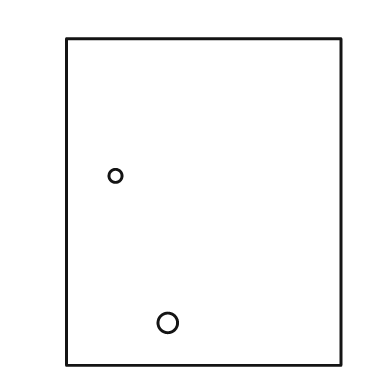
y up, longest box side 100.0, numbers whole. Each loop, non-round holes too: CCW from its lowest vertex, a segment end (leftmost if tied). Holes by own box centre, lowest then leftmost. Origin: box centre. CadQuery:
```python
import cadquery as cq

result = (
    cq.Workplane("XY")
    .moveTo(-42.0, -50.0)
    .lineTo(42.0, -50.0)
    .lineTo(42.0, 50.0)
    .lineTo(-42.0, 50.0)
    .close()
    .moveTo(-11.0, -37.0)
    .circle(3.0)
    .moveTo(-27.0, 8.0)
    .circle(2.0)
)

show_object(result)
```